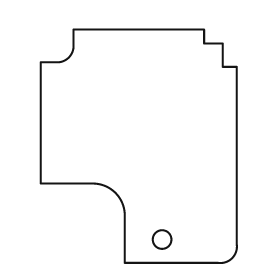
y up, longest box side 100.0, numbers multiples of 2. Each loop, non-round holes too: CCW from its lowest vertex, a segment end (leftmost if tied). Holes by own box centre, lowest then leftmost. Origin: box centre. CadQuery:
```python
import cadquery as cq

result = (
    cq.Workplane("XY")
    .moveTo(-6.0, -50.0)
    .lineTo(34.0, -50.0)
    .threePointArc((40.0, -48.0), (42.0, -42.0))
    .lineTo(42.0, 34.0)
    .lineTo(36.0, 34.0)
    .lineTo(36.0, 44.0)
    .lineTo(28.0, 44.0)
    .lineTo(28.0, 50.0)
    .lineTo(-28.0, 50.0)
    .lineTo(-28.0, 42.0)
    .threePointArc((-30.0, 38.0), (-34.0, 36.0))
    .lineTo(-42.0, 36.0)
    .lineTo(-42.0, -16.0)
    .lineTo(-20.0, -16.0)
    .threePointArc((-10.0, -20.0), (-6.0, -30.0))
    .close()
    .moveTo(10.0, -40.0)
    .circle(4.0)
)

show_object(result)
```